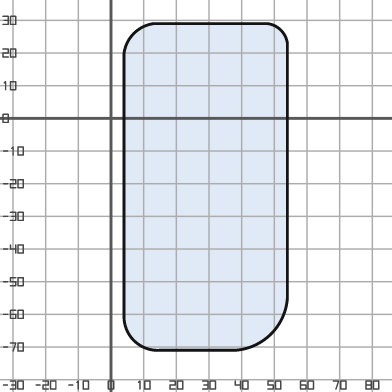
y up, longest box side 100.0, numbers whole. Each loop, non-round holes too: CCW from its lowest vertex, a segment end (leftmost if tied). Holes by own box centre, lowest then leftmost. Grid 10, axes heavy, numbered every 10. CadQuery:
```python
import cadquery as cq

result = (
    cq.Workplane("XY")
    .moveTo(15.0, -71.0)
    .lineTo(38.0, -71.0)
    .threePointArc((49.0, -66.0), (54.0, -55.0))
    .lineTo(54.0, 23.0)
    .threePointArc((52.0, 27.0), (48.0, 29.0))
    .lineTo(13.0, 29.0)
    .threePointArc((7.0, 26.0), (4.0, 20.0))
    .lineTo(4.0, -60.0)
    .threePointArc((7.0, -68.0), (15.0, -71.0))
    .close()
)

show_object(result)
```